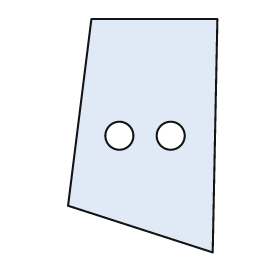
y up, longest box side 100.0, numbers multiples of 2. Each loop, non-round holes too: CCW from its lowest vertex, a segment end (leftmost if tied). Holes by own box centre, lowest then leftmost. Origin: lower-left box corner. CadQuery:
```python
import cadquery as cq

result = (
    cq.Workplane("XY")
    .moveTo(62.0, 0.0)
    .lineTo(64.0, 100.0)
    .lineTo(10.0, 100.0)
    .lineTo(0.0, 20.0)
    .close()
    .moveTo(22.0, 50.0)
    .circle(6.0)
    .moveTo(44.0, 50.0)
    .circle(6.0)
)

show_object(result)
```